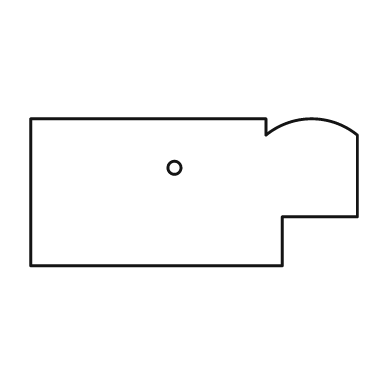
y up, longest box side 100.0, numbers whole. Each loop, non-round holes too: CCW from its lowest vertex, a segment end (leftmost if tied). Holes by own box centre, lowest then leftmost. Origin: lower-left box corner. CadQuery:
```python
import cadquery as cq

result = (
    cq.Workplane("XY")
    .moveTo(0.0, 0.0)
    .lineTo(77.0, 0.0)
    .lineTo(77.0, 15.0)
    .lineTo(100.0, 15.0)
    .lineTo(100.0, 40.0)
    .threePointArc((86.0, 45.0), (72.0, 40.0))
    .lineTo(72.0, 45.0)
    .lineTo(0.0, 45.0)
    .close()
    .moveTo(44.0, 30.0)
    .circle(2.0)
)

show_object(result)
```